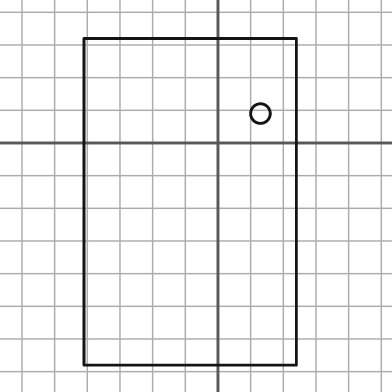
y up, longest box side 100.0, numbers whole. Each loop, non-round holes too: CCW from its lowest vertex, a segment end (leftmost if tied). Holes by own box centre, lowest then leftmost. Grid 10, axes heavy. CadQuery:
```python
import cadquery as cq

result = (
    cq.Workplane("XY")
    .moveTo(-41.0, -68.0)
    .lineTo(24.0, -68.0)
    .lineTo(24.0, 32.0)
    .lineTo(-41.0, 32.0)
    .close()
    .moveTo(13.0, 9.0)
    .circle(3.0)
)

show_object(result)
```